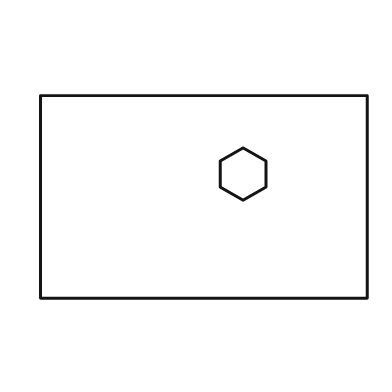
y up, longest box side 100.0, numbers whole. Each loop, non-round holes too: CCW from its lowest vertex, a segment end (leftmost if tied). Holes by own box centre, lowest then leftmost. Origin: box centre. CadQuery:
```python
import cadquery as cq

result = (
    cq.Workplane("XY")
    .moveTo(-50.0, -31.0)
    .lineTo(50.0, -31.0)
    .lineTo(50.0, 31.0)
    .lineTo(-50.0, 31.0)
    .close()
    .moveTo(12.0, -1.0)
    .lineTo(19.0, 3.0)
    .lineTo(19.0, 11.0)
    .lineTo(12.0, 15.0)
    .lineTo(5.0, 11.0)
    .lineTo(5.0, 3.0)
    .close()
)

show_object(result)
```